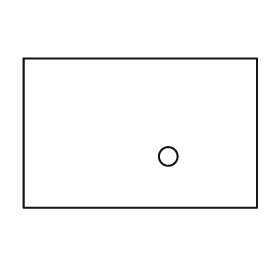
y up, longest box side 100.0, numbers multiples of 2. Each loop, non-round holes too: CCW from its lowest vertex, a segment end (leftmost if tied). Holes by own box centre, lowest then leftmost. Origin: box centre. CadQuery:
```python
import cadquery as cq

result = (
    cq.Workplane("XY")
    .moveTo(-50.0, -32.0)
    .lineTo(50.0, -32.0)
    .lineTo(50.0, 32.0)
    .lineTo(-50.0, 32.0)
    .close()
    .moveTo(12.0, -10.0)
    .circle(4.0)
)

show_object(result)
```